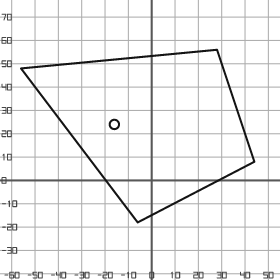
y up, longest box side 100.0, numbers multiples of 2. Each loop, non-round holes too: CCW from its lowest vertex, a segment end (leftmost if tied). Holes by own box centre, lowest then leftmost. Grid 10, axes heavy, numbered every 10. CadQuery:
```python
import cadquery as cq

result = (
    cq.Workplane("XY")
    .moveTo(-6.0, -18.0)
    .lineTo(44.0, 8.0)
    .lineTo(28.0, 56.0)
    .lineTo(-56.0, 48.0)
    .close()
    .moveTo(-16.0, 24.0)
    .circle(2.0)
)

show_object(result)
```